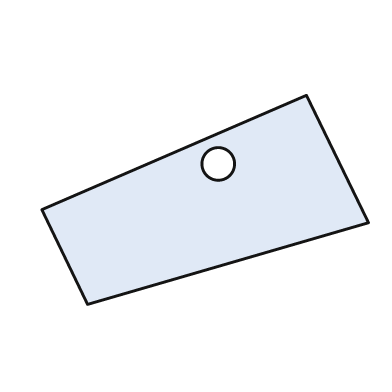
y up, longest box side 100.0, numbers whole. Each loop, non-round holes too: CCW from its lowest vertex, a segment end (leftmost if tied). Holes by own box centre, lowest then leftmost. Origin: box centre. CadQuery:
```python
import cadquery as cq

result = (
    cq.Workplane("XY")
    .moveTo(-36.0, -32.0)
    .lineTo(50.0, -7.0)
    .lineTo(31.0, 32.0)
    .lineTo(-50.0, -3.0)
    .close()
    .moveTo(4.0, 11.0)
    .circle(5.0)
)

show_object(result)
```